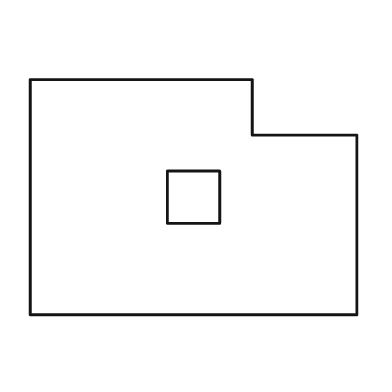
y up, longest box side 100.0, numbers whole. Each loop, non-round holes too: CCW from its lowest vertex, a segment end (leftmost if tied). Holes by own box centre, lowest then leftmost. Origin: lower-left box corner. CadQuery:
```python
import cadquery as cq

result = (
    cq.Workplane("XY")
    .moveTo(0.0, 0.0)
    .lineTo(100.0, 0.0)
    .lineTo(100.0, 55.0)
    .lineTo(68.0, 55.0)
    .lineTo(68.0, 72.0)
    .lineTo(0.0, 72.0)
    .close()
    .moveTo(42.0, 28.0)
    .lineTo(58.0, 28.0)
    .lineTo(58.0, 44.0)
    .lineTo(42.0, 44.0)
    .close()
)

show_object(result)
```